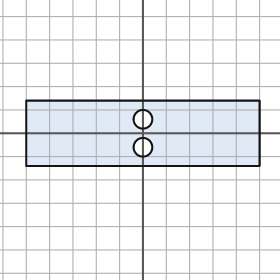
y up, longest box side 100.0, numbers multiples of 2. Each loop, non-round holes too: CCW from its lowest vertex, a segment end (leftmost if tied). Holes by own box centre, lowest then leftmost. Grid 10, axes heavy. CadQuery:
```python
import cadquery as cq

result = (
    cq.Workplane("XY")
    .moveTo(-50.0, -14.0)
    .lineTo(50.0, -14.0)
    .lineTo(50.0, 14.0)
    .lineTo(-50.0, 14.0)
    .close()
    .moveTo(0.0, -6.0)
    .circle(4.0)
    .moveTo(0.0, 6.0)
    .circle(4.0)
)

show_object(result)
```